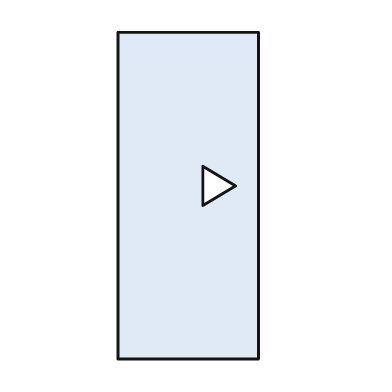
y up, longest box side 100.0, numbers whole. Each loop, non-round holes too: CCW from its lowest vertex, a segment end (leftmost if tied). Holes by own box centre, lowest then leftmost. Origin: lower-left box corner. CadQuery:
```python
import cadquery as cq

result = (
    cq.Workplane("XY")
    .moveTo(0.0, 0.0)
    .lineTo(43.0, 0.0)
    .lineTo(43.0, 100.0)
    .lineTo(0.0, 100.0)
    .close()
    .moveTo(26.0, 47.0)
    .lineTo(36.0, 53.0)
    .lineTo(26.0, 59.0)
    .close()
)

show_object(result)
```